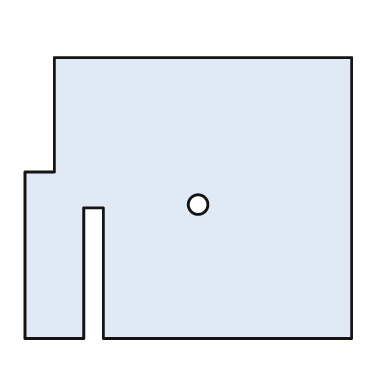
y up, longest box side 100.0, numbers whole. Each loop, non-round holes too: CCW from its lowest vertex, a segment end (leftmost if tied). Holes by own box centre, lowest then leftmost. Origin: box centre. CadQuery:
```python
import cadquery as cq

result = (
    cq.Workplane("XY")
    .moveTo(-50.0, -43.0)
    .lineTo(-32.0, -43.0)
    .lineTo(-32.0, -3.0)
    .lineTo(-26.0, -3.0)
    .lineTo(-26.0, -43.0)
    .lineTo(50.0, -43.0)
    .lineTo(50.0, 43.0)
    .lineTo(-41.0, 43.0)
    .lineTo(-41.0, 8.0)
    .lineTo(-50.0, 8.0)
    .close()
    .moveTo(3.0, -2.0)
    .circle(3.0)
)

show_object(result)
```